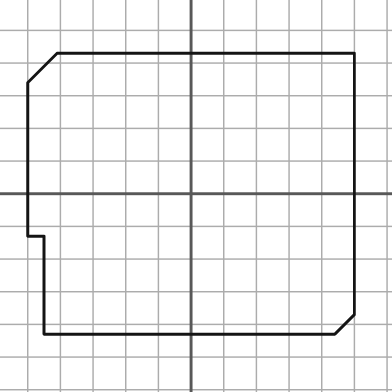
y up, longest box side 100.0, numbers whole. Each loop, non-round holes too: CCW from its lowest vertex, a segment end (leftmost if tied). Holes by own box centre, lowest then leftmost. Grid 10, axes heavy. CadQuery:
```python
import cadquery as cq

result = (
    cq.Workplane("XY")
    .moveTo(-45.0, -43.0)
    .lineTo(44.0, -43.0)
    .lineTo(50.0, -37.0)
    .lineTo(50.0, 43.0)
    .lineTo(-41.0, 43.0)
    .lineTo(-50.0, 34.0)
    .lineTo(-50.0, -13.0)
    .lineTo(-45.0, -13.0)
    .close()
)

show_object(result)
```